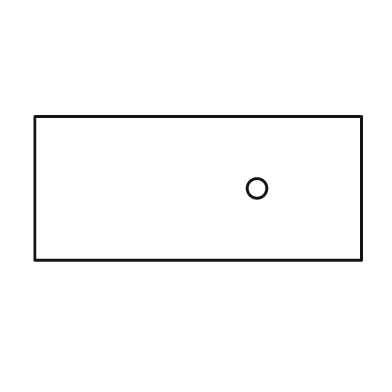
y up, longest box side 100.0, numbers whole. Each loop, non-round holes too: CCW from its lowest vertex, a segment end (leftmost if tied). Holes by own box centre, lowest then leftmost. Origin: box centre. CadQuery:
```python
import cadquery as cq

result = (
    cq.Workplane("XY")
    .moveTo(-50.0, -22.0)
    .lineTo(50.0, -22.0)
    .lineTo(50.0, 22.0)
    .lineTo(-50.0, 22.0)
    .close()
    .moveTo(18.0, 0.0)
    .circle(3.0)
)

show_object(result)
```